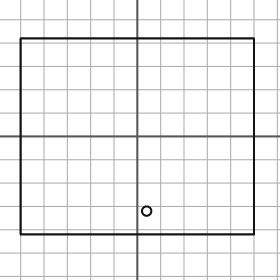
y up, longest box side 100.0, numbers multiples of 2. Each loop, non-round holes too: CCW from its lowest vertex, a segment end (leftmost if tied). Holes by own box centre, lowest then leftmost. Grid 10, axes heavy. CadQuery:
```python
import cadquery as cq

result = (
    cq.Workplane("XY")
    .moveTo(-50.0, -42.0)
    .lineTo(50.0, -42.0)
    .lineTo(50.0, 42.0)
    .lineTo(-50.0, 42.0)
    .close()
    .moveTo(4.0, -32.0)
    .circle(2.0)
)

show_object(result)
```